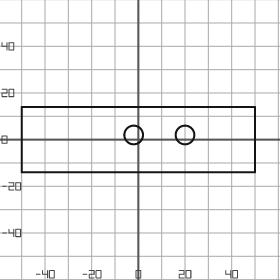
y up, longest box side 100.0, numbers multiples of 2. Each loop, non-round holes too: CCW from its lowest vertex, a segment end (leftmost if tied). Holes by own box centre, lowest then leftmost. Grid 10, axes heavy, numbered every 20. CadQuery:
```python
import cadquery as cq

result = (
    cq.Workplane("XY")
    .moveTo(-50.0, -14.0)
    .lineTo(50.0, -14.0)
    .lineTo(50.0, 14.0)
    .lineTo(-50.0, 14.0)
    .close()
    .moveTo(-2.0, 2.0)
    .circle(4.0)
    .moveTo(20.0, 2.0)
    .circle(4.0)
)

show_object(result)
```